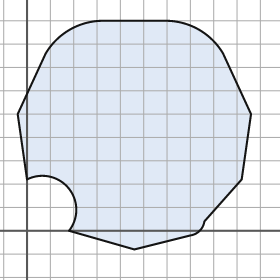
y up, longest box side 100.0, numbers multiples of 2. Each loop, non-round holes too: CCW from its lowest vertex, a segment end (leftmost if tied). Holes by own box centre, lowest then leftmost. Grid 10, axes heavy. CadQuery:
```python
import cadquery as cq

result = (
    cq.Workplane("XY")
    .moveTo(46.0, -8.0)
    .lineTo(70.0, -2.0)
    .threePointArc((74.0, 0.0), (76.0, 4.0))
    .lineTo(92.0, 22.0)
    .lineTo(96.0, 50.0)
    .lineTo(84.0, 76.0)
    .threePointArc((74.0, 86.0), (60.0, 90.0))
    .lineTo(32.0, 90.0)
    .threePointArc((18.0, 86.0), (8.0, 76.0))
    .lineTo(-4.0, 50.0)
    .lineTo(0.0, 22.0)
    .threePointArc((18.0, 18.0), (18.0, 0.0))
    .close()
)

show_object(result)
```